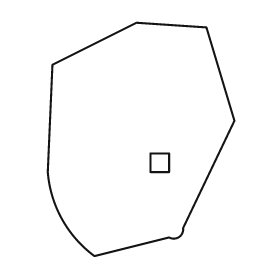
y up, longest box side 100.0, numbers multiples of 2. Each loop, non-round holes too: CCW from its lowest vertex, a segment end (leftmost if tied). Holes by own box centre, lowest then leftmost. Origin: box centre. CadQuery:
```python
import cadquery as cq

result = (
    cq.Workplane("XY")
    .moveTo(-20.0, -50.0)
    .lineTo(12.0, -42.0)
    .threePointArc((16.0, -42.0), (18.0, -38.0))
    .lineTo(40.0, 8.0)
    .lineTo(28.0, 48.0)
    .lineTo(-2.0, 50.0)
    .lineTo(-38.0, 32.0)
    .lineTo(-40.0, -14.0)
    .threePointArc((-34.0, -34.0), (-20.0, -50.0))
    .close()
    .moveTo(4.0, -14.0)
    .lineTo(12.0, -14.0)
    .lineTo(12.0, -6.0)
    .lineTo(4.0, -6.0)
    .close()
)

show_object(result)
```